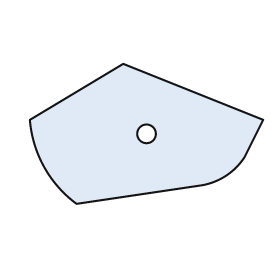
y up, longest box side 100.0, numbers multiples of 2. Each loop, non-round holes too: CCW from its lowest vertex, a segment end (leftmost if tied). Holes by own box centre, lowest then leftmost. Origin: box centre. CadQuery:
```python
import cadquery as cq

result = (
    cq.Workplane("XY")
    .moveTo(-30.0, -30.0)
    .lineTo(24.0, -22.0)
    .threePointArc((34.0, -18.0), (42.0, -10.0))
    .lineTo(50.0, 6.0)
    .lineTo(-10.0, 30.0)
    .lineTo(-50.0, 6.0)
    .threePointArc((-44.0, -14.0), (-30.0, -30.0))
    .close()
    .moveTo(0.0, 0.0)
    .circle(4.0)
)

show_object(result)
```